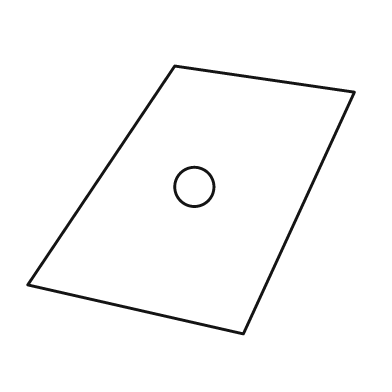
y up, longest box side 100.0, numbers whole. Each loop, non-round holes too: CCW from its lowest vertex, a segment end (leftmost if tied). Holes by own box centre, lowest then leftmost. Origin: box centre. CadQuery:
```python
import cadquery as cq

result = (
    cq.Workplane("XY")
    .moveTo(16.0, -41.0)
    .lineTo(50.0, 33.0)
    .lineTo(-5.0, 41.0)
    .lineTo(-50.0, -26.0)
    .close()
    .moveTo(1.0, 4.0)
    .circle(6.0)
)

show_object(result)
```